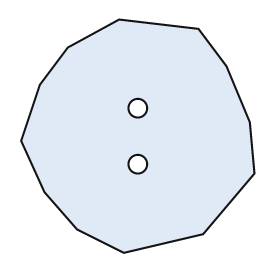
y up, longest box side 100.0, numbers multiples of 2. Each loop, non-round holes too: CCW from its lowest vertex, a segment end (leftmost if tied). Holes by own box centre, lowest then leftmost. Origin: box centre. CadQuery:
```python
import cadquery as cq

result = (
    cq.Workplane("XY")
    .moveTo(-6.0, -50.0)
    .lineTo(28.0, -42.0)
    .lineTo(50.0, -16.0)
    .lineTo(48.0, 6.0)
    .lineTo(38.0, 30.0)
    .lineTo(26.0, 46.0)
    .lineTo(-8.0, 50.0)
    .lineTo(-30.0, 38.0)
    .lineTo(-42.0, 22.0)
    .lineTo(-50.0, -2.0)
    .lineTo(-40.0, -24.0)
    .lineTo(-26.0, -40.0)
    .close()
    .moveTo(0.0, -12.0)
    .circle(4.0)
    .moveTo(0.0, 12.0)
    .circle(4.0)
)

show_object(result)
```